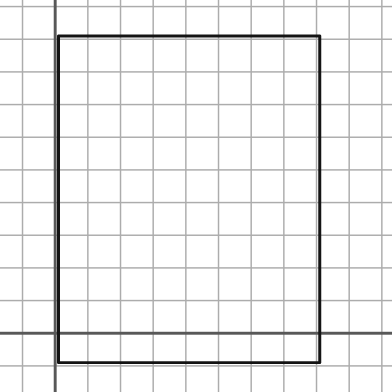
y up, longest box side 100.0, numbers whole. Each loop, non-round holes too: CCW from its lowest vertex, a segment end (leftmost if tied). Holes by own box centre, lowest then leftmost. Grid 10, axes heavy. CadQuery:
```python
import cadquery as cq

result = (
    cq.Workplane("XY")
    .moveTo(1.0, -9.0)
    .lineTo(81.0, -9.0)
    .lineTo(81.0, 91.0)
    .lineTo(1.0, 91.0)
    .close()
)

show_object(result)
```